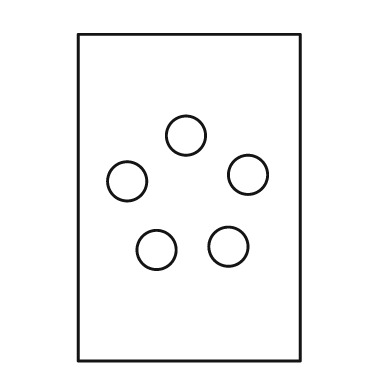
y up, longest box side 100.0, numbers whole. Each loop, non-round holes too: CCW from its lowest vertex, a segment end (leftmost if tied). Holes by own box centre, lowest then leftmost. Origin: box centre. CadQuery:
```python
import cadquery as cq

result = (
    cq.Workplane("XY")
    .moveTo(-34.0, -50.0)
    .lineTo(34.0, -50.0)
    .lineTo(34.0, 50.0)
    .lineTo(-34.0, 50.0)
    .close()
    .moveTo(-10.0, -16.0)
    .circle(6.0)
    .moveTo(12.0, -15.0)
    .circle(6.0)
    .moveTo(-19.0, 5.0)
    .circle(6.0)
    .moveTo(18.0, 7.0)
    .circle(6.0)
    .moveTo(-1.0, 19.0)
    .circle(6.0)
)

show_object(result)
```